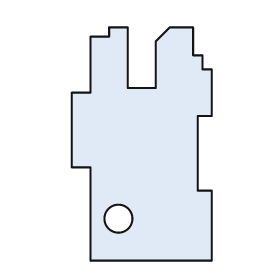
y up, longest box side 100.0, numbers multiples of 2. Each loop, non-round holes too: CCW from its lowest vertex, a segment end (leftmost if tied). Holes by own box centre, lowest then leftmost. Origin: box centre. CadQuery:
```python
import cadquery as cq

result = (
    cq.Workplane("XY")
    .moveTo(-22.0, -50.0)
    .lineTo(30.0, -50.0)
    .lineTo(30.0, -20.0)
    .lineTo(24.0, -20.0)
    .lineTo(24.0, 12.0)
    .lineTo(30.0, 12.0)
    .lineTo(30.0, 32.0)
    .lineTo(26.0, 32.0)
    .lineTo(26.0, 38.0)
    .lineTo(22.0, 38.0)
    .lineTo(22.0, 50.0)
    .lineTo(12.0, 50.0)
    .lineTo(6.0, 44.0)
    .lineTo(6.0, 24.0)
    .lineTo(-6.0, 24.0)
    .lineTo(-6.0, 50.0)
    .lineTo(-14.0, 50.0)
    .lineTo(-14.0, 46.0)
    .lineTo(-22.0, 46.0)
    .lineTo(-22.0, 22.0)
    .lineTo(-30.0, 22.0)
    .lineTo(-30.0, -10.0)
    .lineTo(-22.0, -10.0)
    .close()
    .moveTo(-10.0, -32.0)
    .circle(6.0)
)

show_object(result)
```